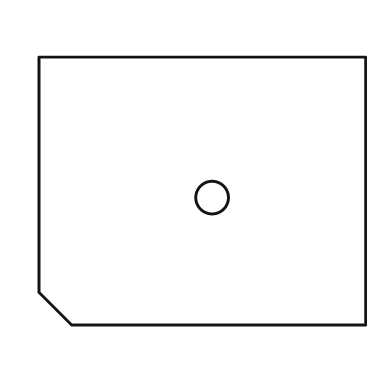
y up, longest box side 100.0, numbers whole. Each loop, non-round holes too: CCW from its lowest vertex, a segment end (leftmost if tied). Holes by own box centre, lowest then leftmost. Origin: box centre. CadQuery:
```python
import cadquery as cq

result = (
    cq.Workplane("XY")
    .moveTo(-40.0, -41.0)
    .lineTo(50.0, -41.0)
    .lineTo(50.0, 41.0)
    .lineTo(-50.0, 41.0)
    .lineTo(-50.0, -31.0)
    .close()
    .moveTo(3.0, -2.0)
    .circle(5.0)
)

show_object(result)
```